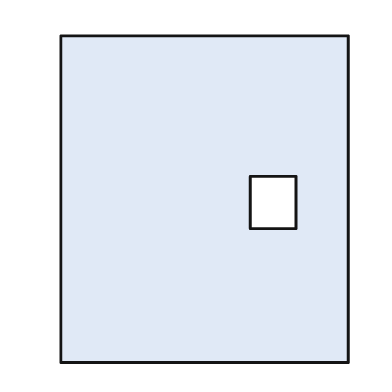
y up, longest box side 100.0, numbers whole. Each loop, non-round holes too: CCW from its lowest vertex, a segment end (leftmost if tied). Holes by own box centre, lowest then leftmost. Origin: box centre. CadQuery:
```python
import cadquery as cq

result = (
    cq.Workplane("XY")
    .moveTo(-44.0, -50.0)
    .lineTo(44.0, -50.0)
    .lineTo(44.0, 50.0)
    .lineTo(-44.0, 50.0)
    .close()
    .moveTo(14.0, -9.0)
    .lineTo(28.0, -9.0)
    .lineTo(28.0, 7.0)
    .lineTo(14.0, 7.0)
    .close()
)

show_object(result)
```